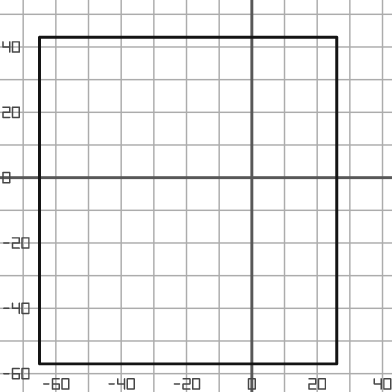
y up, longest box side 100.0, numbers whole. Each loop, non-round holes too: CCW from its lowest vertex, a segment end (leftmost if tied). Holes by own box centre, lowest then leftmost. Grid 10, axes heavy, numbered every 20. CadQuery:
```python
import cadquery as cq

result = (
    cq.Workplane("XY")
    .moveTo(-65.0, -57.0)
    .lineTo(26.0, -57.0)
    .lineTo(26.0, 43.0)
    .lineTo(-65.0, 43.0)
    .close()
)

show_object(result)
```